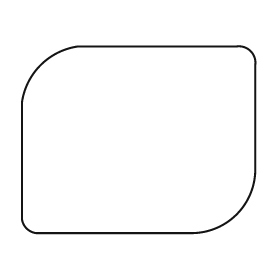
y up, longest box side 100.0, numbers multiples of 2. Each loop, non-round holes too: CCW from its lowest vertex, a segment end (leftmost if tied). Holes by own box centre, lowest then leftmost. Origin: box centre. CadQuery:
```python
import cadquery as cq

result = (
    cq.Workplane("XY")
    .moveTo(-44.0, -40.0)
    .lineTo(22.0, -40.0)
    .threePointArc((42.0, -32.0), (50.0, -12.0))
    .lineTo(50.0, 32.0)
    .threePointArc((48.0, 38.0), (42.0, 40.0))
    .lineTo(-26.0, 40.0)
    .threePointArc((-42.0, 32.0), (-50.0, 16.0))
    .lineTo(-50.0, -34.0)
    .threePointArc((-48.0, -38.0), (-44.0, -40.0))
    .close()
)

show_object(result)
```